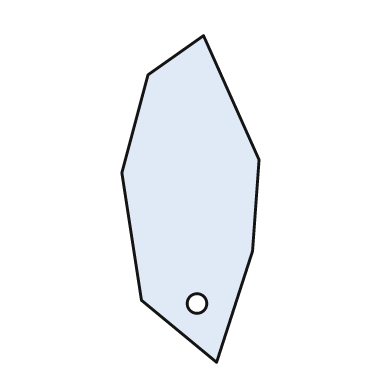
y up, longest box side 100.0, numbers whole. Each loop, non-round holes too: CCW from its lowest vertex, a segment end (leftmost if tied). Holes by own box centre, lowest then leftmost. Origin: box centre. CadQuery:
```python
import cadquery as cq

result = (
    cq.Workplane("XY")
    .moveTo(8.0, -50.0)
    .lineTo(19.0, -16.0)
    .lineTo(21.0, 12.0)
    .lineTo(4.0, 50.0)
    .lineTo(-13.0, 38.0)
    .lineTo(-21.0, 8.0)
    .lineTo(-15.0, -31.0)
    .close()
    .moveTo(2.0, -32.0)
    .circle(3.0)
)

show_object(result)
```